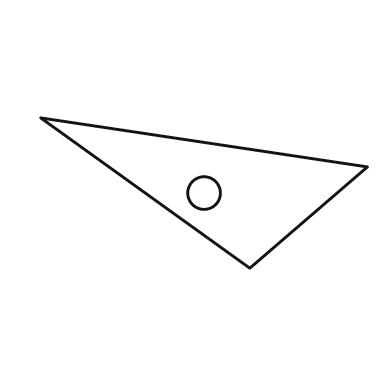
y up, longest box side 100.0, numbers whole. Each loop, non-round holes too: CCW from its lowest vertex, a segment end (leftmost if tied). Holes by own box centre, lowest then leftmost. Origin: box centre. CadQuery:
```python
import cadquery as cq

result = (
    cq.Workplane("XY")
    .moveTo(14.0, -23.0)
    .lineTo(50.0, 8.0)
    .lineTo(-50.0, 23.0)
    .close()
    .moveTo(0.0, 0.0)
    .circle(5.0)
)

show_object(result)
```